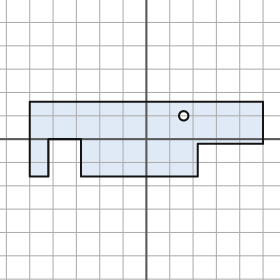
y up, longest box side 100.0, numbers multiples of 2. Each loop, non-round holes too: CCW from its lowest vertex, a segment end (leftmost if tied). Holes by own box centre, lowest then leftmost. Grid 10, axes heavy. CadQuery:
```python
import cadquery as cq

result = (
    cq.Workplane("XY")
    .moveTo(-50.0, -16.0)
    .lineTo(-42.0, -16.0)
    .lineTo(-42.0, 0.0)
    .lineTo(-28.0, 0.0)
    .lineTo(-28.0, -16.0)
    .lineTo(22.0, -16.0)
    .lineTo(22.0, -2.0)
    .lineTo(50.0, -2.0)
    .lineTo(50.0, 16.0)
    .lineTo(-50.0, 16.0)
    .close()
    .moveTo(16.0, 10.0)
    .circle(2.0)
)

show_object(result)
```